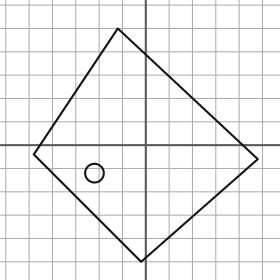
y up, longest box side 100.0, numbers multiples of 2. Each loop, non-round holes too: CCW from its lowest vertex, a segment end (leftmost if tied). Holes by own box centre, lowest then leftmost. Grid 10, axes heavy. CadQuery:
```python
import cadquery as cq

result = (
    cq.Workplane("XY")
    .moveTo(-2.0, -50.0)
    .lineTo(48.0, -6.0)
    .lineTo(-12.0, 50.0)
    .lineTo(-48.0, -4.0)
    .close()
    .moveTo(-22.0, -12.0)
    .circle(4.0)
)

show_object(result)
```